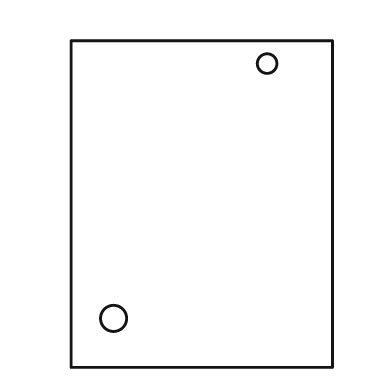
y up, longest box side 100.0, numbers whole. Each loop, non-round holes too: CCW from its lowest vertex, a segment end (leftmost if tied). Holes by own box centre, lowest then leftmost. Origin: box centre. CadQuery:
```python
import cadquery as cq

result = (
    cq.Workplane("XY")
    .moveTo(-40.0, -50.0)
    .lineTo(40.0, -50.0)
    .lineTo(40.0, 50.0)
    .lineTo(-40.0, 50.0)
    .close()
    .moveTo(-27.0, -35.0)
    .circle(4.0)
    .moveTo(20.0, 43.0)
    .circle(3.0)
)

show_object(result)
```